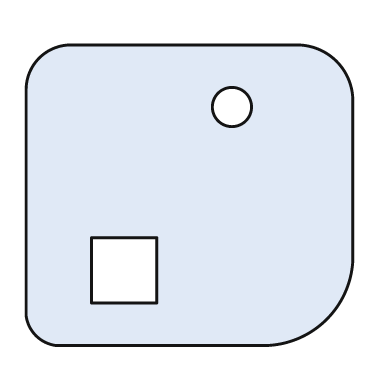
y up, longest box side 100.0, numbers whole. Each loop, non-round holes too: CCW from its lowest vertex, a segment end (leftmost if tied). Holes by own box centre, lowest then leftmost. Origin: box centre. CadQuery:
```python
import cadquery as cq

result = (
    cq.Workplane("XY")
    .moveTo(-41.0, -46.0)
    .lineTo(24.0, -46.0)
    .threePointArc((42.0, -38.0), (50.0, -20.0))
    .lineTo(50.0, 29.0)
    .threePointArc((45.0, 41.0), (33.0, 46.0))
    .lineTo(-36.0, 46.0)
    .threePointArc((-46.0, 42.0), (-50.0, 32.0))
    .lineTo(-50.0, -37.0)
    .threePointArc((-47.0, -43.0), (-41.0, -46.0))
    .close()
    .moveTo(-30.0, -33.0)
    .lineTo(-10.0, -33.0)
    .lineTo(-10.0, -13.0)
    .lineTo(-30.0, -13.0)
    .close()
    .moveTo(13.0, 27.0)
    .circle(6.0)
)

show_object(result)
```